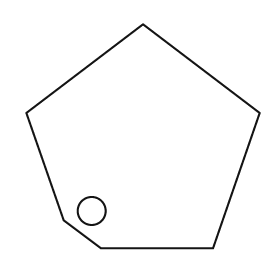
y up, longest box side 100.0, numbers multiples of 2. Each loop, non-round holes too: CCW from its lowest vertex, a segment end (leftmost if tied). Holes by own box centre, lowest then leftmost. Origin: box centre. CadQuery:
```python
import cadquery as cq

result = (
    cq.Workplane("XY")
    .moveTo(-18.0, -48.0)
    .lineTo(30.0, -48.0)
    .lineTo(50.0, 10.0)
    .lineTo(0.0, 48.0)
    .lineTo(-50.0, 10.0)
    .lineTo(-34.0, -36.0)
    .close()
    .moveTo(-22.0, -32.0)
    .circle(6.0)
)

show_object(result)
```